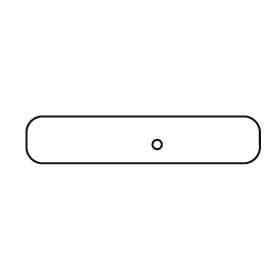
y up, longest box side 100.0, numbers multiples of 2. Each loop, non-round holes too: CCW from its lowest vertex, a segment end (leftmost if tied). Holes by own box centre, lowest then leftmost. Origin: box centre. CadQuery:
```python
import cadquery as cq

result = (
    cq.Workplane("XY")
    .moveTo(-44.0, -10.0)
    .lineTo(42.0, -10.0)
    .threePointArc((48.0, -8.0), (50.0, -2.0))
    .lineTo(50.0, 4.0)
    .threePointArc((48.0, 8.0), (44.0, 10.0))
    .lineTo(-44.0, 10.0)
    .threePointArc((-48.0, 8.0), (-50.0, 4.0))
    .lineTo(-50.0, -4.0)
    .threePointArc((-48.0, -8.0), (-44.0, -10.0))
    .close()
    .moveTo(6.0, -2.0)
    .circle(2.0)
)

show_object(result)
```